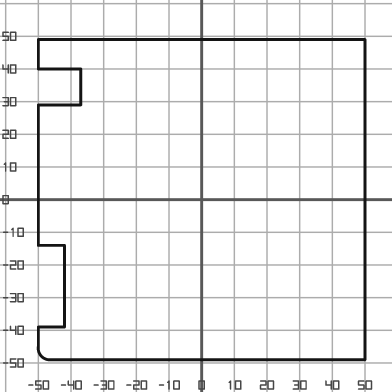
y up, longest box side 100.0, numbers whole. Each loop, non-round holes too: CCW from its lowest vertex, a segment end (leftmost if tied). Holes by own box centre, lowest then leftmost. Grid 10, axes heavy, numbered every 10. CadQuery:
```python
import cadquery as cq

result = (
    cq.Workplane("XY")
    .moveTo(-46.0, -49.0)
    .lineTo(50.0, -49.0)
    .lineTo(50.0, 49.0)
    .lineTo(-50.0, 49.0)
    .lineTo(-50.0, 40.0)
    .lineTo(-37.0, 40.0)
    .lineTo(-37.0, 29.0)
    .lineTo(-50.0, 29.0)
    .lineTo(-50.0, -14.0)
    .lineTo(-42.0, -14.0)
    .lineTo(-42.0, -39.0)
    .lineTo(-50.0, -39.0)
    .lineTo(-50.0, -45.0)
    .threePointArc((-49.0, -48.0), (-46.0, -49.0))
    .close()
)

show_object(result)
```